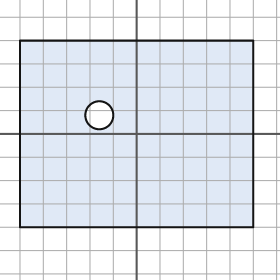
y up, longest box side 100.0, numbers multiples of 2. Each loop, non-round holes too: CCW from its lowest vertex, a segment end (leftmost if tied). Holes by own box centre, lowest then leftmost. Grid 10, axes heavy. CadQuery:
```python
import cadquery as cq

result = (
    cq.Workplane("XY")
    .moveTo(-50.0, -40.0)
    .lineTo(50.0, -40.0)
    .lineTo(50.0, 40.0)
    .lineTo(-50.0, 40.0)
    .close()
    .moveTo(-16.0, 8.0)
    .circle(6.0)
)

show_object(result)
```